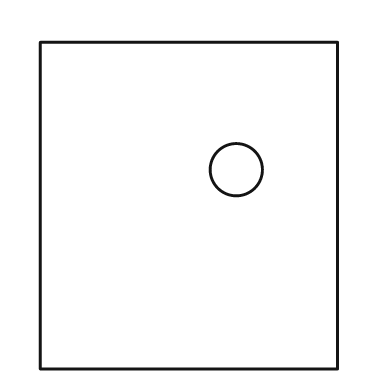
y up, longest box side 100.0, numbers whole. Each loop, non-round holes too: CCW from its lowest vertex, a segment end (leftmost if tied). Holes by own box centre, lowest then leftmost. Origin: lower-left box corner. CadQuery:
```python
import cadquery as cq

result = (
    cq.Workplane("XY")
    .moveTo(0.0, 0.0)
    .lineTo(91.0, 0.0)
    .lineTo(91.0, 100.0)
    .lineTo(0.0, 100.0)
    .close()
    .moveTo(60.0, 61.0)
    .circle(8.0)
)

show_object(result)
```